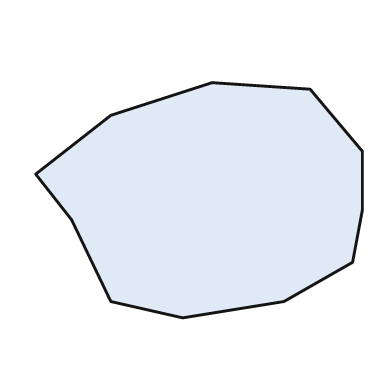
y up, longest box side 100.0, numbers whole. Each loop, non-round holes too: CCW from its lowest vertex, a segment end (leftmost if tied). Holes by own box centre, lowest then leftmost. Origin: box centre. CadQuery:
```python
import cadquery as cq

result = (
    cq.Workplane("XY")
    .moveTo(-5.0, -36.0)
    .lineTo(26.0, -31.0)
    .lineTo(47.0, -19.0)
    .lineTo(50.0, -3.0)
    .lineTo(50.0, 15.0)
    .lineTo(34.0, 34.0)
    .lineTo(4.0, 36.0)
    .lineTo(-27.0, 26.0)
    .lineTo(-50.0, 8.0)
    .lineTo(-39.0, -6.0)
    .lineTo(-27.0, -31.0)
    .close()
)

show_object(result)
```